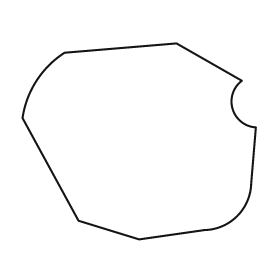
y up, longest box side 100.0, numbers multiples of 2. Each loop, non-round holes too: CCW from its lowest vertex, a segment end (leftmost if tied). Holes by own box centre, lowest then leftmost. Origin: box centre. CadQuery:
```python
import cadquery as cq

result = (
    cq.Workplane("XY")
    .moveTo(0.0, -42.0)
    .lineTo(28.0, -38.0)
    .threePointArc((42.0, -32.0), (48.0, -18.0))
    .lineTo(50.0, 6.0)
    .threePointArc((40.0, 14.0), (44.0, 26.0))
    .lineTo(16.0, 42.0)
    .lineTo(-32.0, 38.0)
    .threePointArc((-44.0, 26.0), (-50.0, 10.0))
    .lineTo(-26.0, -34.0)
    .close()
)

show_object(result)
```